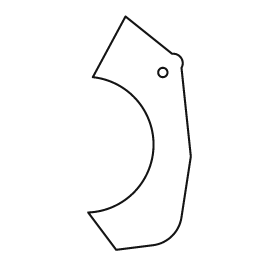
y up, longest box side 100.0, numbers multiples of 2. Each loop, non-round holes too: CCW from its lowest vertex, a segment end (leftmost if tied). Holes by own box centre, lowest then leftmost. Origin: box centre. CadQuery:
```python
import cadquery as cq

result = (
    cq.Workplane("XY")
    .moveTo(-10.0, -50.0)
    .lineTo(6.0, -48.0)
    .threePointArc((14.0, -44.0), (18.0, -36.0))
    .lineTo(22.0, -10.0)
    .lineTo(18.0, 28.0)
    .threePointArc((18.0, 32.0), (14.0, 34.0))
    .lineTo(-6.0, 50.0)
    .lineTo(-20.0, 24.0)
    .threePointArc((6.0, -6.0), (-22.0, -34.0))
    .close()
    .moveTo(10.0, 26.0)
    .circle(2.0)
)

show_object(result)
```